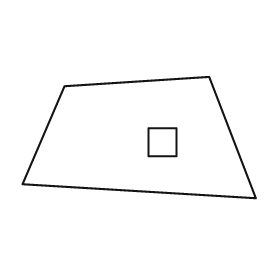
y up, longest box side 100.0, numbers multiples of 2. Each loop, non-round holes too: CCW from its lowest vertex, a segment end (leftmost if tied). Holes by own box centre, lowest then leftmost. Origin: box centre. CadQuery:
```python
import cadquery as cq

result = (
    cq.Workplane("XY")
    .moveTo(50.0, -26.0)
    .lineTo(30.0, 26.0)
    .lineTo(-32.0, 22.0)
    .lineTo(-50.0, -20.0)
    .close()
    .moveTo(4.0, -8.0)
    .lineTo(16.0, -8.0)
    .lineTo(16.0, 4.0)
    .lineTo(4.0, 4.0)
    .close()
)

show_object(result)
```